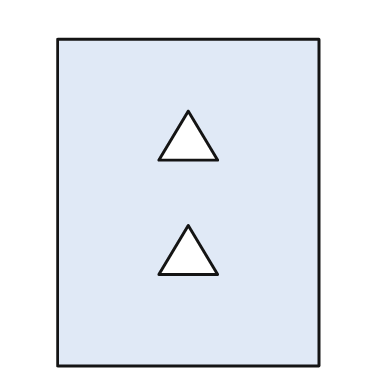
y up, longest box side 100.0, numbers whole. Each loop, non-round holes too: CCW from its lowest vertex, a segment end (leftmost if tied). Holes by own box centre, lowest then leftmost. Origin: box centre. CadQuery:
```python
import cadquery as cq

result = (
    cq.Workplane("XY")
    .moveTo(-40.0, -50.0)
    .lineTo(40.0, -50.0)
    .lineTo(40.0, 50.0)
    .lineTo(-40.0, 50.0)
    .close()
    .moveTo(-9.0, -22.0)
    .lineTo(9.0, -22.0)
    .lineTo(0.0, -7.0)
    .close()
    .moveTo(-9.0, 13.0)
    .lineTo(9.0, 13.0)
    .lineTo(0.0, 28.0)
    .close()
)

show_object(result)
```